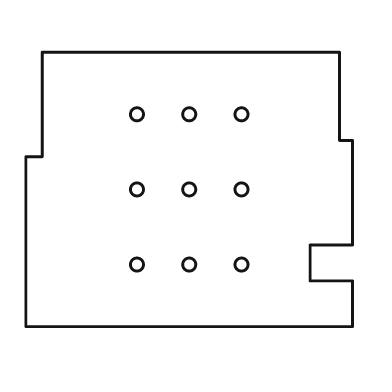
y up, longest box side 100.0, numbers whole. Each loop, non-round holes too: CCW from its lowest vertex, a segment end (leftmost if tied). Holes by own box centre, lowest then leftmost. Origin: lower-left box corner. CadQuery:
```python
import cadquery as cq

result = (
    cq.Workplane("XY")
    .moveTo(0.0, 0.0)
    .lineTo(100.0, 0.0)
    .lineTo(100.0, 14.0)
    .lineTo(87.0, 14.0)
    .lineTo(87.0, 25.0)
    .lineTo(100.0, 25.0)
    .lineTo(100.0, 57.0)
    .lineTo(96.0, 57.0)
    .lineTo(96.0, 84.0)
    .lineTo(5.0, 84.0)
    .lineTo(5.0, 52.0)
    .lineTo(0.0, 52.0)
    .close()
    .moveTo(34.0, 19.0)
    .circle(2.0)
    .moveTo(50.0, 19.0)
    .circle(2.0)
    .moveTo(66.0, 19.0)
    .circle(2.0)
    .moveTo(34.0, 42.0)
    .circle(2.0)
    .moveTo(50.0, 42.0)
    .circle(2.0)
    .moveTo(66.0, 42.0)
    .circle(2.0)
    .moveTo(34.0, 65.0)
    .circle(2.0)
    .moveTo(50.0, 65.0)
    .circle(2.0)
    .moveTo(66.0, 65.0)
    .circle(2.0)
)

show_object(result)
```